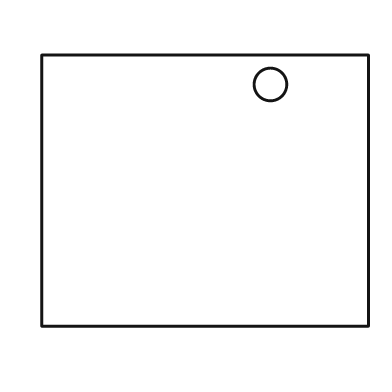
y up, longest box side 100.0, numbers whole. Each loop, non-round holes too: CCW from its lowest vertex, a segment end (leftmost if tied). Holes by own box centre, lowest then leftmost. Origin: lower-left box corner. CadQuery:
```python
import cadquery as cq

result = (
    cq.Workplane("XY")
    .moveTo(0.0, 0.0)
    .lineTo(100.0, 0.0)
    .lineTo(100.0, 83.0)
    .lineTo(0.0, 83.0)
    .close()
    .moveTo(70.0, 74.0)
    .circle(5.0)
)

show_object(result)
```